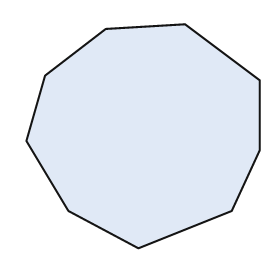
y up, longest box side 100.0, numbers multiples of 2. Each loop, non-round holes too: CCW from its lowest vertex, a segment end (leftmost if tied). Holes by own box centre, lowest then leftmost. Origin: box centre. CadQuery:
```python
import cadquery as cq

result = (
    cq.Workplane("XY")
    .moveTo(-2.0, -48.0)
    .lineTo(38.0, -32.0)
    .lineTo(50.0, -6.0)
    .lineTo(50.0, 24.0)
    .lineTo(18.0, 48.0)
    .lineTo(-16.0, 46.0)
    .lineTo(-42.0, 26.0)
    .lineTo(-50.0, -2.0)
    .lineTo(-32.0, -32.0)
    .close()
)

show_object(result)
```